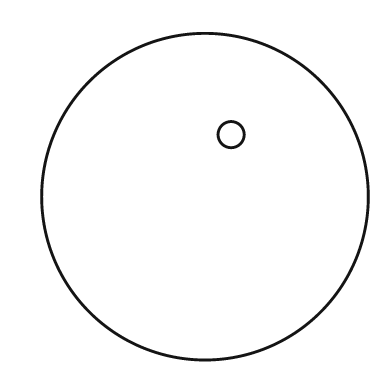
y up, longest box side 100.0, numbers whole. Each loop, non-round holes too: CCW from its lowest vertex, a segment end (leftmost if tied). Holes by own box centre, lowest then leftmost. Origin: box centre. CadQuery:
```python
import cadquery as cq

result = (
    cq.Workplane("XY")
    .moveTo(0.0, 0.0)
    .circle(50.0)
    .moveTo(8.0, 19.0)
    .circle(4.0)
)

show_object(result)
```